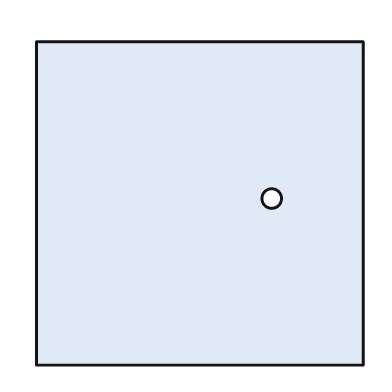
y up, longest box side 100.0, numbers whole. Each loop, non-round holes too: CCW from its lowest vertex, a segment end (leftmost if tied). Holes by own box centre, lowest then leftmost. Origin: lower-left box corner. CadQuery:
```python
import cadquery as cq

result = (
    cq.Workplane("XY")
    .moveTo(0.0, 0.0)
    .lineTo(100.0, 0.0)
    .lineTo(100.0, 99.0)
    .lineTo(0.0, 99.0)
    .close()
    .moveTo(72.0, 51.0)
    .circle(3.0)
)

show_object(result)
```